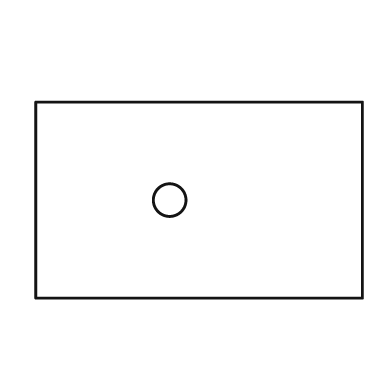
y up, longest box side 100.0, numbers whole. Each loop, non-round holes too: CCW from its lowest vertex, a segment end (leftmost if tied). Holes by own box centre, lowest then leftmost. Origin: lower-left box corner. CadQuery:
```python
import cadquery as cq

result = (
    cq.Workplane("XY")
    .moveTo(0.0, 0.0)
    .lineTo(100.0, 0.0)
    .lineTo(100.0, 60.0)
    .lineTo(0.0, 60.0)
    .close()
    .moveTo(41.0, 30.0)
    .circle(5.0)
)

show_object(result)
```